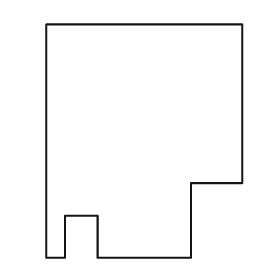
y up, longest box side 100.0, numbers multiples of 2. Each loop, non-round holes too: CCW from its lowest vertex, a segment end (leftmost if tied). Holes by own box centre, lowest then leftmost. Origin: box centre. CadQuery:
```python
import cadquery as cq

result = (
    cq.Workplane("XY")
    .moveTo(-42.0, -50.0)
    .lineTo(-34.0, -50.0)
    .lineTo(-34.0, -32.0)
    .lineTo(-20.0, -32.0)
    .lineTo(-20.0, -50.0)
    .lineTo(20.0, -50.0)
    .lineTo(20.0, -18.0)
    .lineTo(42.0, -18.0)
    .lineTo(42.0, 50.0)
    .lineTo(-42.0, 50.0)
    .close()
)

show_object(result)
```